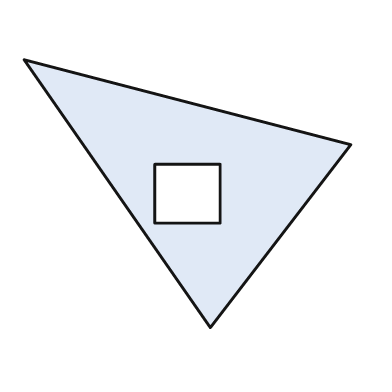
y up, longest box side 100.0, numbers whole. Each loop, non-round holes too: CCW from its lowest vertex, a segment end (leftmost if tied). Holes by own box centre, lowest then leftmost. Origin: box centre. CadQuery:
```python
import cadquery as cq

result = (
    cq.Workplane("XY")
    .moveTo(7.0, -41.0)
    .lineTo(50.0, 15.0)
    .lineTo(-50.0, 41.0)
    .close()
    .moveTo(-10.0, -9.0)
    .lineTo(10.0, -9.0)
    .lineTo(10.0, 9.0)
    .lineTo(-10.0, 9.0)
    .close()
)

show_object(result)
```